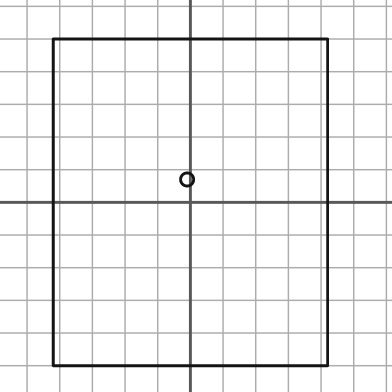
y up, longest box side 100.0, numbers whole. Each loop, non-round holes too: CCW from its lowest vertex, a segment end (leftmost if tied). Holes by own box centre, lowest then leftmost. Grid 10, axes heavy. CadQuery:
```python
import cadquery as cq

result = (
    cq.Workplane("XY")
    .moveTo(-42.0, -50.0)
    .lineTo(42.0, -50.0)
    .lineTo(42.0, 50.0)
    .lineTo(-42.0, 50.0)
    .close()
    .moveTo(-1.0, 7.0)
    .circle(2.0)
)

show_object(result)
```